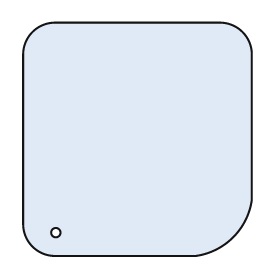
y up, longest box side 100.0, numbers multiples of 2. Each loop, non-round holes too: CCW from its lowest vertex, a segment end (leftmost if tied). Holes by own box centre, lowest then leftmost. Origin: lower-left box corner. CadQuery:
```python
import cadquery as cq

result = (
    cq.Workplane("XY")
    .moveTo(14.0, 0.0)
    .lineTo(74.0, 0.0)
    .threePointArc((90.0, 8.0), (98.0, 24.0))
    .lineTo(98.0, 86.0)
    .threePointArc((94.0, 96.0), (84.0, 100.0))
    .lineTo(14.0, 100.0)
    .threePointArc((4.0, 96.0), (0.0, 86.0))
    .lineTo(0.0, 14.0)
    .threePointArc((4.0, 4.0), (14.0, 0.0))
    .close()
    .moveTo(14.0, 10.0)
    .circle(2.0)
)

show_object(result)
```